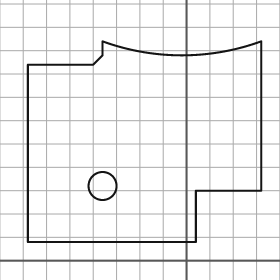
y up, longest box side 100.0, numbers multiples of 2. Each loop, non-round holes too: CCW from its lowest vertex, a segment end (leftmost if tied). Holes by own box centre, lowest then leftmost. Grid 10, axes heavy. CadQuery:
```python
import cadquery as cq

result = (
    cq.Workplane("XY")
    .moveTo(-68.0, 8.0)
    .lineTo(4.0, 8.0)
    .lineTo(4.0, 30.0)
    .lineTo(32.0, 30.0)
    .lineTo(32.0, 94.0)
    .threePointArc((-2.0, 88.0), (-36.0, 94.0))
    .lineTo(-36.0, 88.0)
    .lineTo(-40.0, 84.0)
    .lineTo(-68.0, 84.0)
    .close()
    .moveTo(-36.0, 32.0)
    .circle(6.0)
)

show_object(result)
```